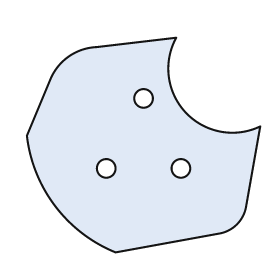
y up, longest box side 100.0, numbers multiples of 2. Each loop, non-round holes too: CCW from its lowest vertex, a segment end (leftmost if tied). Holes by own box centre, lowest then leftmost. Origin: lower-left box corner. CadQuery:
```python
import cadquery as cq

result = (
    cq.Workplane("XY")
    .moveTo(38.0, 0.0)
    .lineTo(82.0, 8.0)
    .threePointArc((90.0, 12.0), (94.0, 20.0))
    .lineTo(100.0, 54.0)
    .threePointArc((68.0, 60.0), (64.0, 92.0))
    .lineTo(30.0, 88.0)
    .threePointArc((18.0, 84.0), (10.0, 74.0))
    .lineTo(0.0, 50.0)
    .threePointArc((12.0, 20.0), (38.0, 0.0))
    .close()
    .moveTo(34.0, 36.0)
    .circle(4.0)
    .moveTo(66.0, 36.0)
    .circle(4.0)
    .moveTo(50.0, 66.0)
    .circle(4.0)
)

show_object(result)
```